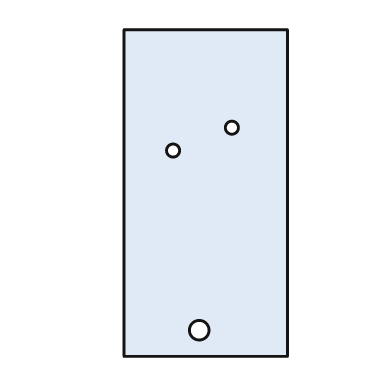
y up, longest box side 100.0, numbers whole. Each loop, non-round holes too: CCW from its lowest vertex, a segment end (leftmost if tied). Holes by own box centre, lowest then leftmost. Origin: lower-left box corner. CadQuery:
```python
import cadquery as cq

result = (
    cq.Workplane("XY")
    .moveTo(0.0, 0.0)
    .lineTo(50.0, 0.0)
    .lineTo(50.0, 100.0)
    .lineTo(0.0, 100.0)
    .close()
    .moveTo(23.0, 8.0)
    .circle(3.0)
    .moveTo(15.0, 63.0)
    .circle(2.0)
    .moveTo(33.0, 70.0)
    .circle(2.0)
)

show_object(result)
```